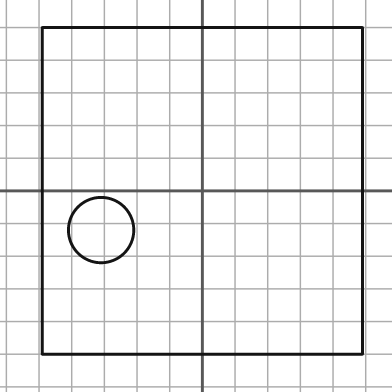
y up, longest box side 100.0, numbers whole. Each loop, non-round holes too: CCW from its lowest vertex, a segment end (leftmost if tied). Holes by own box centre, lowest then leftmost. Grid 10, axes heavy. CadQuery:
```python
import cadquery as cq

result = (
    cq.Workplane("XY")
    .moveTo(-49.0, -50.0)
    .lineTo(49.0, -50.0)
    .lineTo(49.0, 50.0)
    .lineTo(-49.0, 50.0)
    .close()
    .moveTo(-31.0, -12.0)
    .circle(10.0)
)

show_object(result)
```